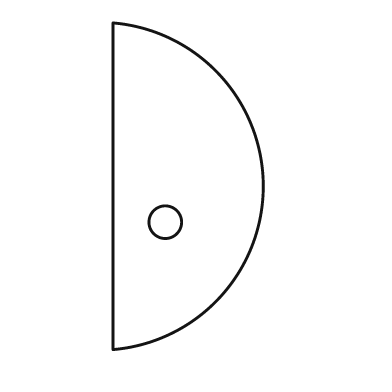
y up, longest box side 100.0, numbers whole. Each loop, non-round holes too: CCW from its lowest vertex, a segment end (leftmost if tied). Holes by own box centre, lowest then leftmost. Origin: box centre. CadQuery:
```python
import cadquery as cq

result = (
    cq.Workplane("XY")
    .moveTo(-23.0, -50.0)
    .threePointArc((23.0, 0.0), (-23.0, 50.0))
    .close()
    .moveTo(-7.0, -11.0)
    .circle(5.0)
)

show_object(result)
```